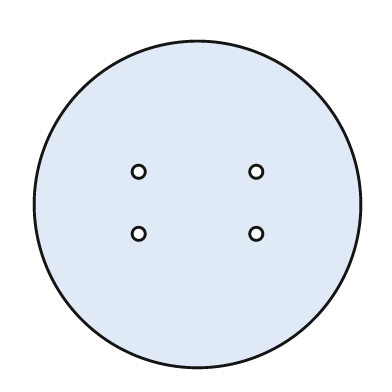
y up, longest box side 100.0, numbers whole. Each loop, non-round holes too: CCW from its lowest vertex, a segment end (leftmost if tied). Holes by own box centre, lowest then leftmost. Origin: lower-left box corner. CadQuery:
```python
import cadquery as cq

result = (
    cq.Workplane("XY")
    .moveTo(50.0, 50.0)
    .circle(50.0)
    .moveTo(32.0, 41.0)
    .circle(2.0)
    .moveTo(68.0, 41.0)
    .circle(2.0)
    .moveTo(32.0, 60.0)
    .circle(2.0)
    .moveTo(68.0, 60.0)
    .circle(2.0)
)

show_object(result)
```